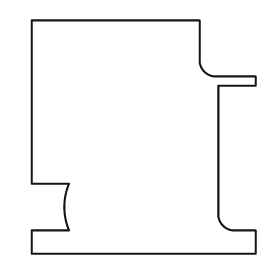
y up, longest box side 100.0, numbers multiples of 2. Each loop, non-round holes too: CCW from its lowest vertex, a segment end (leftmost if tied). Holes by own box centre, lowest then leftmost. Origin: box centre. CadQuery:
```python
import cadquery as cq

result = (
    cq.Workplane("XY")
    .moveTo(-48.0, -50.0)
    .lineTo(48.0, -50.0)
    .lineTo(48.0, -40.0)
    .lineTo(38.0, -40.0)
    .threePointArc((34.0, -38.0), (32.0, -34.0))
    .lineTo(32.0, 22.0)
    .lineTo(48.0, 22.0)
    .lineTo(48.0, 26.0)
    .lineTo(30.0, 26.0)
    .threePointArc((26.0, 28.0), (24.0, 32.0))
    .lineTo(24.0, 50.0)
    .lineTo(-48.0, 50.0)
    .lineTo(-48.0, -20.0)
    .lineTo(-32.0, -20.0)
    .threePointArc((-34.0, -30.0), (-32.0, -40.0))
    .lineTo(-48.0, -40.0)
    .close()
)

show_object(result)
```